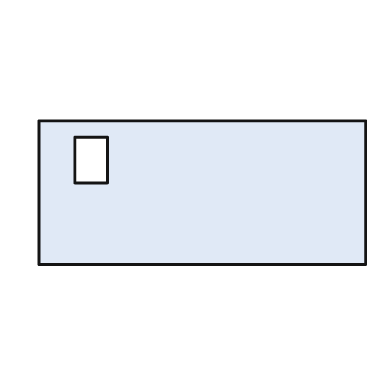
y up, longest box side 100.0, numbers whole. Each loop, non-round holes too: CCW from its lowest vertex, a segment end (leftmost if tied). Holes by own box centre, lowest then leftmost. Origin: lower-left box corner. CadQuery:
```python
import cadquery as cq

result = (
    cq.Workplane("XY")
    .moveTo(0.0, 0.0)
    .lineTo(100.0, 0.0)
    .lineTo(100.0, 44.0)
    .lineTo(0.0, 44.0)
    .close()
    .moveTo(11.0, 25.0)
    .lineTo(21.0, 25.0)
    .lineTo(21.0, 39.0)
    .lineTo(11.0, 39.0)
    .close()
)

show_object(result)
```